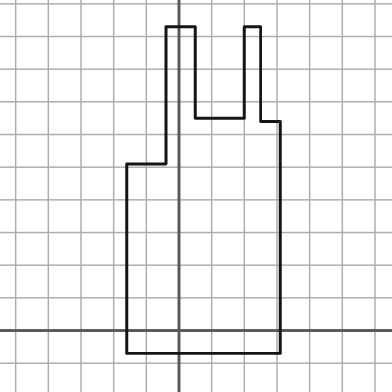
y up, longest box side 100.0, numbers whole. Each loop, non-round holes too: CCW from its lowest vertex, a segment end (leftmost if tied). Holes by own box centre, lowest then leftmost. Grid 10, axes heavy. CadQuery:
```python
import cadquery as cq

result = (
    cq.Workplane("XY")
    .moveTo(-16.0, -7.0)
    .lineTo(31.0, -7.0)
    .lineTo(31.0, 64.0)
    .lineTo(25.0, 64.0)
    .lineTo(25.0, 93.0)
    .lineTo(20.0, 93.0)
    .lineTo(20.0, 65.0)
    .lineTo(5.0, 65.0)
    .lineTo(5.0, 93.0)
    .lineTo(-4.0, 93.0)
    .lineTo(-4.0, 51.0)
    .lineTo(-16.0, 51.0)
    .close()
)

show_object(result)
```